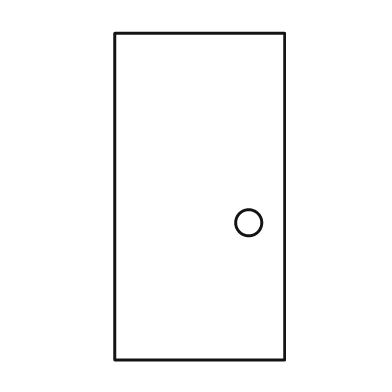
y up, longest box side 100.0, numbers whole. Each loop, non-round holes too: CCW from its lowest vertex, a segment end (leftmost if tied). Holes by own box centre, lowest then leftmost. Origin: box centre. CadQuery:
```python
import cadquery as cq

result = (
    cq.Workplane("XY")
    .moveTo(-26.0, -50.0)
    .lineTo(26.0, -50.0)
    .lineTo(26.0, 50.0)
    .lineTo(-26.0, 50.0)
    .close()
    .moveTo(15.0, -8.0)
    .circle(4.0)
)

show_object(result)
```